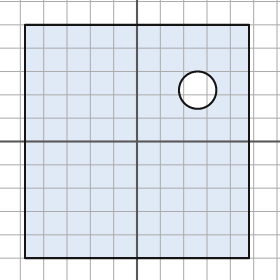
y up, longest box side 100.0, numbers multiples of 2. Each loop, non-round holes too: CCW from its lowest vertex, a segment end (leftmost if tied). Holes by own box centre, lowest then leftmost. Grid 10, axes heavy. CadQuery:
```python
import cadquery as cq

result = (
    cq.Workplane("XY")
    .moveTo(-48.0, -50.0)
    .lineTo(48.0, -50.0)
    .lineTo(48.0, 50.0)
    .lineTo(-48.0, 50.0)
    .close()
    .moveTo(26.0, 22.0)
    .circle(8.0)
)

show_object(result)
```